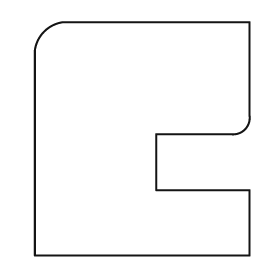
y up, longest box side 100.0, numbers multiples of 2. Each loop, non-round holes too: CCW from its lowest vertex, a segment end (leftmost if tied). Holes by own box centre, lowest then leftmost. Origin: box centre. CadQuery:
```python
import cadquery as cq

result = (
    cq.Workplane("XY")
    .moveTo(-46.0, -50.0)
    .lineTo(46.0, -50.0)
    .lineTo(46.0, -22.0)
    .lineTo(6.0, -22.0)
    .lineTo(6.0, 2.0)
    .lineTo(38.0, 2.0)
    .threePointArc((44.0, 4.0), (46.0, 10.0))
    .lineTo(46.0, 50.0)
    .lineTo(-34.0, 50.0)
    .threePointArc((-42.0, 46.0), (-46.0, 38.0))
    .close()
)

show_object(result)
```